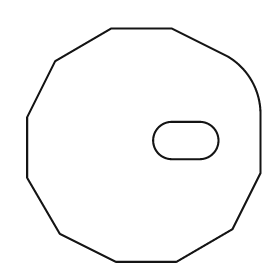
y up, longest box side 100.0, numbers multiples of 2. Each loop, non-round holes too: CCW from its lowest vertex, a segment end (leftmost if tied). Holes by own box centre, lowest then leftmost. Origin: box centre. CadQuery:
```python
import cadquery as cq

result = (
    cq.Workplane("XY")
    .moveTo(-12.0, -50.0)
    .lineTo(14.0, -50.0)
    .lineTo(38.0, -36.0)
    .lineTo(50.0, -12.0)
    .lineTo(50.0, 14.0)
    .threePointArc((46.0, 28.0), (36.0, 38.0))
    .lineTo(12.0, 50.0)
    .lineTo(-14.0, 50.0)
    .lineTo(-38.0, 36.0)
    .lineTo(-50.0, 12.0)
    .lineTo(-50.0, -14.0)
    .lineTo(-36.0, -38.0)
    .close()
    .moveTo(12.0, -6.0)
    .lineTo(24.0, -6.0)
    .threePointArc((32.0, 2.0), (24.0, 10.0))
    .lineTo(12.0, 10.0)
    .threePointArc((4.0, 2.0), (12.0, -6.0))
    .close()
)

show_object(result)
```